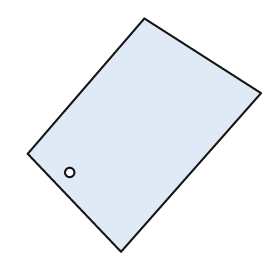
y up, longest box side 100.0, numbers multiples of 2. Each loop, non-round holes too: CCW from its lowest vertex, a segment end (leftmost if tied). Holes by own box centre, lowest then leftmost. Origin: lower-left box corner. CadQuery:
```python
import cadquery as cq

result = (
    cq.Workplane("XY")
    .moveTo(40.0, 0.0)
    .lineTo(100.0, 68.0)
    .lineTo(50.0, 100.0)
    .lineTo(0.0, 42.0)
    .close()
    .moveTo(18.0, 34.0)
    .circle(2.0)
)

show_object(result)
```